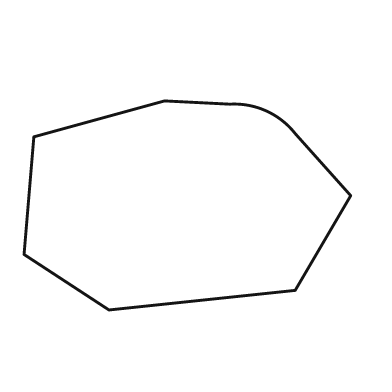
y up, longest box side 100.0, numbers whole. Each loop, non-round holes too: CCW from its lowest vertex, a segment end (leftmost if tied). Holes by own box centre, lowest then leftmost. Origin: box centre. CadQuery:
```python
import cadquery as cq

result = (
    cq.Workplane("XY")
    .moveTo(-24.0, -32.0)
    .lineTo(33.0, -26.0)
    .lineTo(50.0, 3.0)
    .lineTo(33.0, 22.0)
    .threePointArc((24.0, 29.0), (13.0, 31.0))
    .lineTo(-7.0, 32.0)
    .lineTo(-47.0, 21.0)
    .lineTo(-50.0, -15.0)
    .close()
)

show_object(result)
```